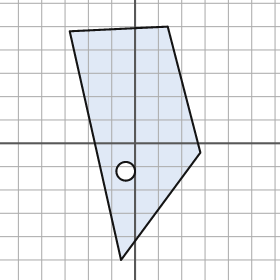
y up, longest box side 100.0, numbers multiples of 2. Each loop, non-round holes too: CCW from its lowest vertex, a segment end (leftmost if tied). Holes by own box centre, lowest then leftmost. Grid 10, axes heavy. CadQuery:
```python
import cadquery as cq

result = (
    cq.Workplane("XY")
    .moveTo(-6.0, -50.0)
    .lineTo(28.0, -4.0)
    .lineTo(14.0, 50.0)
    .lineTo(-28.0, 48.0)
    .close()
    .moveTo(-4.0, -12.0)
    .circle(4.0)
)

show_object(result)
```